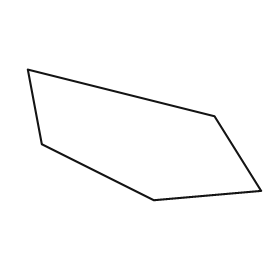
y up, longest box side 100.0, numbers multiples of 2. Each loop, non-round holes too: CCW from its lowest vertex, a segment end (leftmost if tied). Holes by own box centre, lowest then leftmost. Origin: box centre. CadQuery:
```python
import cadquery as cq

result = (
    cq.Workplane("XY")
    .moveTo(4.0, -28.0)
    .lineTo(50.0, -24.0)
    .lineTo(30.0, 8.0)
    .lineTo(-50.0, 28.0)
    .lineTo(-44.0, -4.0)
    .close()
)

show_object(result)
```